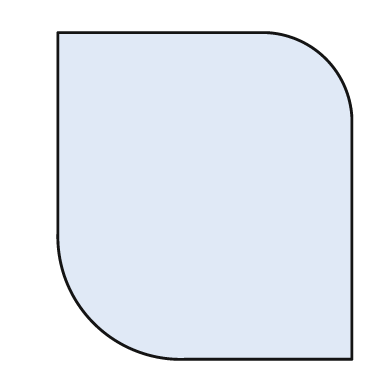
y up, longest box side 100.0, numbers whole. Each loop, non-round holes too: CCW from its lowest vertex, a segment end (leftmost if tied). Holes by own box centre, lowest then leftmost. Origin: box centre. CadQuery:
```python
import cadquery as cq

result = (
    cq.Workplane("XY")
    .moveTo(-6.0, -50.0)
    .lineTo(45.0, -50.0)
    .lineTo(45.0, 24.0)
    .threePointArc((37.0, 42.0), (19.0, 50.0))
    .lineTo(-45.0, 50.0)
    .lineTo(-45.0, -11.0)
    .threePointArc((-34.0, -39.0), (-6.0, -50.0))
    .close()
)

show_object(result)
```